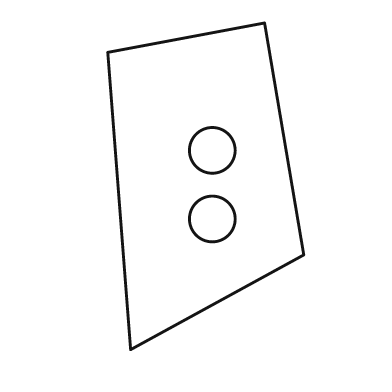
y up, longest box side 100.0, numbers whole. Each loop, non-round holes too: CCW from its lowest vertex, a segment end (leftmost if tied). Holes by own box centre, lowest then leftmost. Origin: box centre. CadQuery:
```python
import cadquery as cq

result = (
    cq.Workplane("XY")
    .moveTo(-23.0, -50.0)
    .lineTo(30.0, -21.0)
    .lineTo(18.0, 50.0)
    .lineTo(-30.0, 41.0)
    .close()
    .moveTo(2.0, -10.0)
    .circle(7.0)
    .moveTo(2.0, 11.0)
    .circle(7.0)
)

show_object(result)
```